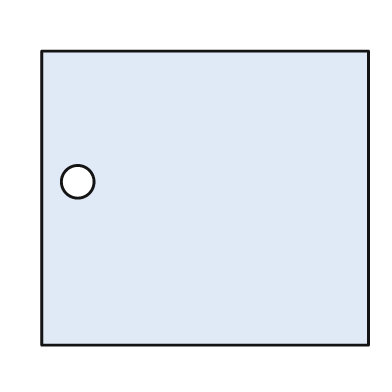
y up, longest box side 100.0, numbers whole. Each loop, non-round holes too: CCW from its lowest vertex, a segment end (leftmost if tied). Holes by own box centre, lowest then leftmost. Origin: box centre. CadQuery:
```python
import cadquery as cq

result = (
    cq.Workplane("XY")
    .moveTo(-50.0, -45.0)
    .lineTo(50.0, -45.0)
    .lineTo(50.0, 45.0)
    .lineTo(-50.0, 45.0)
    .close()
    .moveTo(-39.0, 5.0)
    .circle(5.0)
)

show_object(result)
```